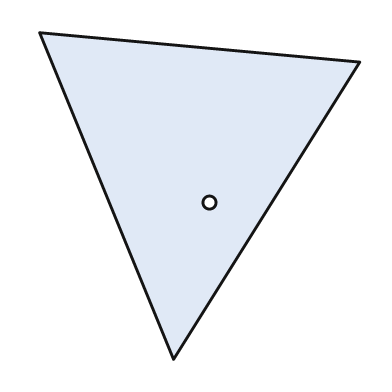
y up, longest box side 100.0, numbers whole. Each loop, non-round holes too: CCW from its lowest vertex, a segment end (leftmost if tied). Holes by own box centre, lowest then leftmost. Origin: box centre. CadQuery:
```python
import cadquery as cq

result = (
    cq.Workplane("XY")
    .moveTo(-8.0, -50.0)
    .lineTo(49.0, 41.0)
    .lineTo(-49.0, 50.0)
    .close()
    .moveTo(3.0, -2.0)
    .circle(2.0)
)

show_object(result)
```